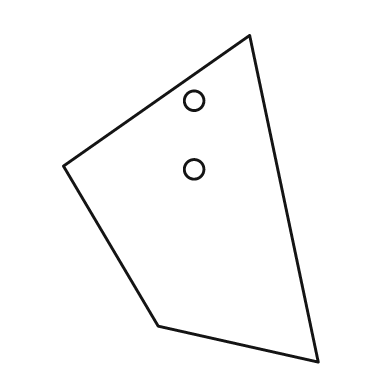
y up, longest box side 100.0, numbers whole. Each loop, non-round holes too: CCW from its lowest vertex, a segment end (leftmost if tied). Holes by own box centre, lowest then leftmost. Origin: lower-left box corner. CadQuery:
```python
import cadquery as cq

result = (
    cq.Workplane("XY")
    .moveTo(78.0, 0.0)
    .lineTo(57.0, 100.0)
    .lineTo(0.0, 60.0)
    .lineTo(29.0, 11.0)
    .close()
    .moveTo(40.0, 59.0)
    .circle(3.0)
    .moveTo(40.0, 80.0)
    .circle(3.0)
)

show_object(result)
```